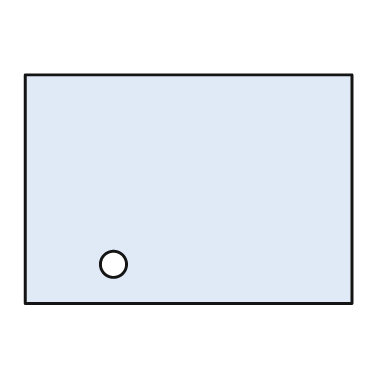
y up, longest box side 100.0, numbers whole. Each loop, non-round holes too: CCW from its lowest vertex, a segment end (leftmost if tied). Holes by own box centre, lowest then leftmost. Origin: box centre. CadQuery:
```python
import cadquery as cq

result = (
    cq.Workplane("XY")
    .moveTo(-50.0, -35.0)
    .lineTo(50.0, -35.0)
    .lineTo(50.0, 35.0)
    .lineTo(-50.0, 35.0)
    .close()
    .moveTo(-23.0, -23.0)
    .circle(4.0)
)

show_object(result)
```